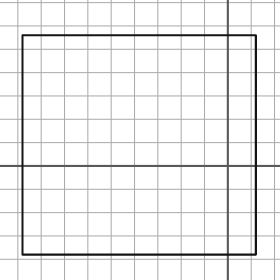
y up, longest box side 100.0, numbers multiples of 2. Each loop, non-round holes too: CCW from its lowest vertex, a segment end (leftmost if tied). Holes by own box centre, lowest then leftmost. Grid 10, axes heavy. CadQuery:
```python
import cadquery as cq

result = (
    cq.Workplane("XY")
    .moveTo(-88.0, -38.0)
    .lineTo(12.0, -38.0)
    .lineTo(12.0, 56.0)
    .lineTo(-88.0, 56.0)
    .close()
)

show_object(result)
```